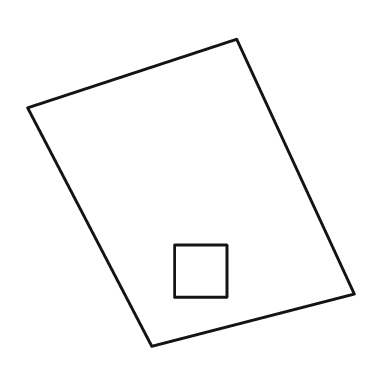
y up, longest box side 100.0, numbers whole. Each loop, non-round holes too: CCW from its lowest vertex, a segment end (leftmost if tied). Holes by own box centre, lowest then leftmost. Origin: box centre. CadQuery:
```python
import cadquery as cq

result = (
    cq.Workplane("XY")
    .moveTo(-12.0, -47.0)
    .lineTo(50.0, -31.0)
    .lineTo(14.0, 47.0)
    .lineTo(-50.0, 26.0)
    .close()
    .moveTo(-5.0, -32.0)
    .lineTo(11.0, -32.0)
    .lineTo(11.0, -16.0)
    .lineTo(-5.0, -16.0)
    .close()
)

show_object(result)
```